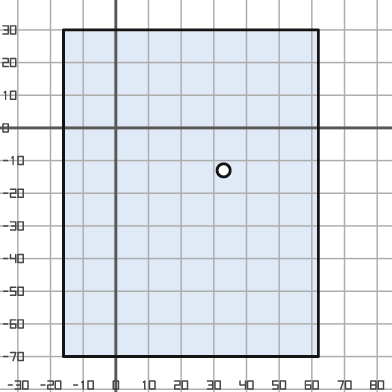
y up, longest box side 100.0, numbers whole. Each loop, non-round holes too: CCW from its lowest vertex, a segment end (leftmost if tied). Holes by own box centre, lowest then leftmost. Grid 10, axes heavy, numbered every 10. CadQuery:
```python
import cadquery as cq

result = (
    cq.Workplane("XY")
    .moveTo(-16.0, -70.0)
    .lineTo(62.0, -70.0)
    .lineTo(62.0, 30.0)
    .lineTo(-16.0, 30.0)
    .close()
    .moveTo(33.0, -13.0)
    .circle(2.0)
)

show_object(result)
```